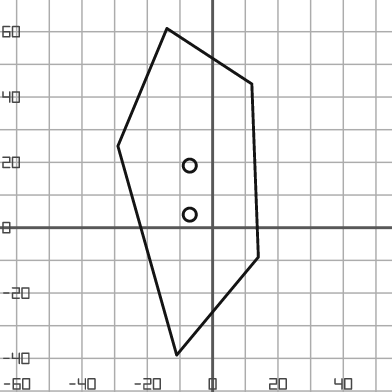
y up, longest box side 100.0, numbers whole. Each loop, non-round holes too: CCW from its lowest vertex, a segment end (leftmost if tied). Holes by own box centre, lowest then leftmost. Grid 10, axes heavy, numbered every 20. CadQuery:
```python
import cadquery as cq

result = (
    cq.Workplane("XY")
    .moveTo(-11.0, -39.0)
    .lineTo(14.0, -9.0)
    .lineTo(12.0, 44.0)
    .lineTo(-14.0, 61.0)
    .lineTo(-29.0, 25.0)
    .close()
    .moveTo(-7.0, 4.0)
    .circle(2.0)
    .moveTo(-7.0, 19.0)
    .circle(2.0)
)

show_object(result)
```